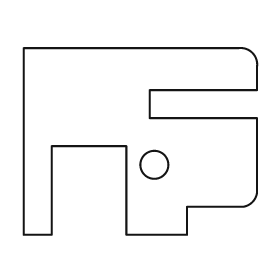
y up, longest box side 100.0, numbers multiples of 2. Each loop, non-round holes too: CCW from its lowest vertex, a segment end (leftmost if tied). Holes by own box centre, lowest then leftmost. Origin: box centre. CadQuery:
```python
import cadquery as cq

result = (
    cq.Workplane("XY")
    .moveTo(-50.0, -40.0)
    .lineTo(-38.0, -40.0)
    .lineTo(-38.0, -2.0)
    .lineTo(-6.0, -2.0)
    .lineTo(-6.0, -40.0)
    .lineTo(20.0, -40.0)
    .lineTo(20.0, -28.0)
    .lineTo(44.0, -28.0)
    .threePointArc((48.0, -26.0), (50.0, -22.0))
    .lineTo(50.0, 10.0)
    .lineTo(4.0, 10.0)
    .lineTo(4.0, 22.0)
    .lineTo(50.0, 22.0)
    .lineTo(50.0, 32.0)
    .threePointArc((48.0, 38.0), (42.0, 40.0))
    .lineTo(-50.0, 40.0)
    .close()
    .moveTo(6.0, -10.0)
    .circle(6.0)
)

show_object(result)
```